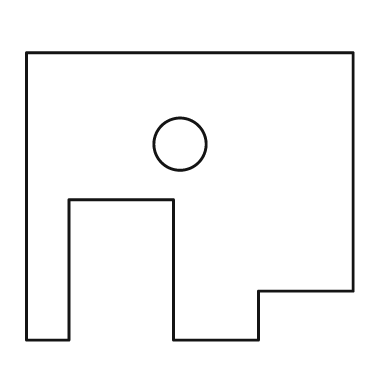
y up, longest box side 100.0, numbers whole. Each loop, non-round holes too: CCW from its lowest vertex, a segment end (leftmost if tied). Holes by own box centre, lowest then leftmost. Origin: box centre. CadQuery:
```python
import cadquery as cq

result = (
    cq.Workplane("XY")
    .moveTo(-50.0, -44.0)
    .lineTo(-37.0, -44.0)
    .lineTo(-37.0, -1.0)
    .lineTo(-5.0, -1.0)
    .lineTo(-5.0, -44.0)
    .lineTo(21.0, -44.0)
    .lineTo(21.0, -29.0)
    .lineTo(50.0, -29.0)
    .lineTo(50.0, 44.0)
    .lineTo(-50.0, 44.0)
    .close()
    .moveTo(-3.0, 16.0)
    .circle(8.0)
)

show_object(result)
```